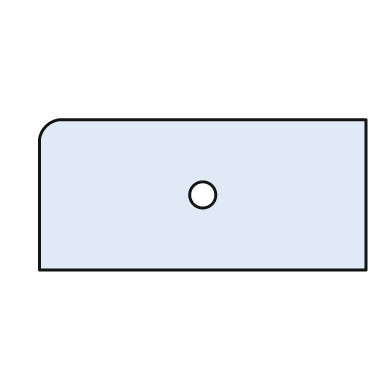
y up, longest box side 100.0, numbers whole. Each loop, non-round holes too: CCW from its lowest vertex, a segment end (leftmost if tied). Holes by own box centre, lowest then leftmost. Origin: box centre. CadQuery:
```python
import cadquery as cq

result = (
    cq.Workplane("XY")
    .moveTo(-50.0, -23.0)
    .lineTo(50.0, -23.0)
    .lineTo(50.0, 23.0)
    .lineTo(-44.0, 23.0)
    .threePointArc((-48.0, 21.0), (-50.0, 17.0))
    .close()
    .moveTo(0.0, 0.0)
    .circle(4.0)
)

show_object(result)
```